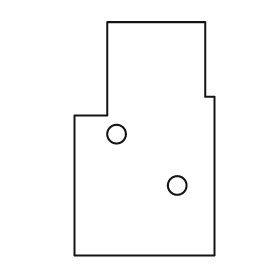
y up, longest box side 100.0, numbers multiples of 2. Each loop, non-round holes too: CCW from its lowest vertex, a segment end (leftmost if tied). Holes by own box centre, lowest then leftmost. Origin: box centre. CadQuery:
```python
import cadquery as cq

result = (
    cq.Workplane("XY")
    .moveTo(-30.0, -50.0)
    .lineTo(30.0, -50.0)
    .lineTo(30.0, 18.0)
    .lineTo(26.0, 18.0)
    .lineTo(26.0, 50.0)
    .lineTo(-16.0, 50.0)
    .lineTo(-16.0, 10.0)
    .lineTo(-30.0, 10.0)
    .close()
    .moveTo(14.0, -20.0)
    .circle(4.0)
    .moveTo(-12.0, 2.0)
    .circle(4.0)
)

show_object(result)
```